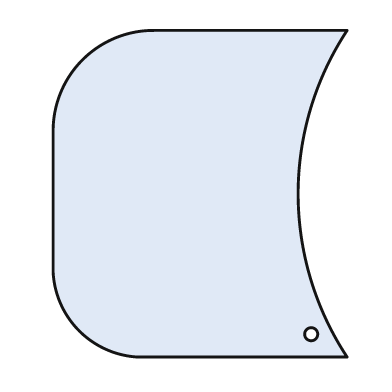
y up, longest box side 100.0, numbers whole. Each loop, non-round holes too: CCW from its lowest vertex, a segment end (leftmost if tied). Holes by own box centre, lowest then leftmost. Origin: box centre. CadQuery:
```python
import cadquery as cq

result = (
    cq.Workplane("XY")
    .moveTo(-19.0, -50.0)
    .lineTo(45.0, -50.0)
    .threePointArc((30.0, 0.0), (45.0, 50.0))
    .lineTo(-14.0, 50.0)
    .threePointArc((-36.0, 41.0), (-45.0, 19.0))
    .lineTo(-45.0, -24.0)
    .threePointArc((-37.0, -42.0), (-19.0, -50.0))
    .close()
    .moveTo(34.0, -43.0)
    .circle(2.0)
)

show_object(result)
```